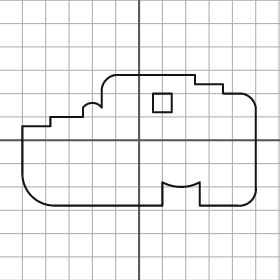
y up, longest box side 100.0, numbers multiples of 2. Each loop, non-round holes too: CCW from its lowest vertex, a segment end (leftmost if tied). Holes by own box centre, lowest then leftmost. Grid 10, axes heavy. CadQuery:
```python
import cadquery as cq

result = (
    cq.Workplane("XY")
    .moveTo(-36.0, -28.0)
    .lineTo(10.0, -28.0)
    .lineTo(10.0, -18.0)
    .threePointArc((18.0, -20.0), (26.0, -18.0))
    .lineTo(26.0, -28.0)
    .lineTo(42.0, -28.0)
    .threePointArc((48.0, -26.0), (50.0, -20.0))
    .lineTo(50.0, 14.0)
    .threePointArc((48.0, 18.0), (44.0, 20.0))
    .lineTo(36.0, 20.0)
    .lineTo(36.0, 24.0)
    .lineTo(24.0, 24.0)
    .lineTo(24.0, 28.0)
    .lineTo(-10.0, 28.0)
    .threePointArc((-14.0, 26.0), (-16.0, 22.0))
    .lineTo(-16.0, 14.0)
    .threePointArc((-20.0, 16.0), (-24.0, 14.0))
    .lineTo(-24.0, 10.0)
    .lineTo(-38.0, 10.0)
    .lineTo(-38.0, 6.0)
    .lineTo(-50.0, 6.0)
    .lineTo(-50.0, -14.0)
    .threePointArc((-46.0, -24.0), (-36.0, -28.0))
    .close()
    .moveTo(6.0, 12.0)
    .lineTo(14.0, 12.0)
    .lineTo(14.0, 20.0)
    .lineTo(6.0, 20.0)
    .close()
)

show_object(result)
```